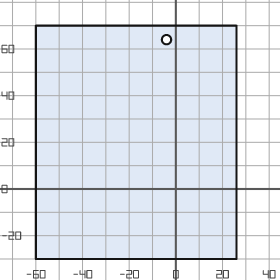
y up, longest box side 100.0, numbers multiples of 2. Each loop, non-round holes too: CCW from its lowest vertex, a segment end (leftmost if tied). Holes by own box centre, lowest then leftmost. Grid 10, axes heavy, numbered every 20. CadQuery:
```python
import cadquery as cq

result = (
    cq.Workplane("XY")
    .moveTo(-60.0, -30.0)
    .lineTo(26.0, -30.0)
    .lineTo(26.0, 70.0)
    .lineTo(-60.0, 70.0)
    .close()
    .moveTo(-4.0, 64.0)
    .circle(2.0)
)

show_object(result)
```